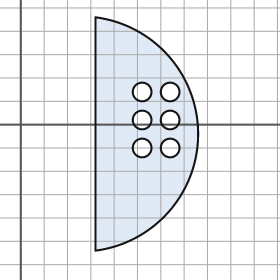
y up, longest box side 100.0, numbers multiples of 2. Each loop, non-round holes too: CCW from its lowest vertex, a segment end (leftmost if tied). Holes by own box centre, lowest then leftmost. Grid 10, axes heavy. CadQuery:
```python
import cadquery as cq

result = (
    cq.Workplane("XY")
    .moveTo(32.0, -54.0)
    .threePointArc((76.0, -4.0), (32.0, 46.0))
    .close()
    .moveTo(52.0, -10.0)
    .circle(4.0)
    .moveTo(64.0, -10.0)
    .circle(4.0)
    .moveTo(52.0, 2.0)
    .circle(4.0)
    .moveTo(64.0, 2.0)
    .circle(4.0)
    .moveTo(52.0, 14.0)
    .circle(4.0)
    .moveTo(64.0, 14.0)
    .circle(4.0)
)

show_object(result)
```